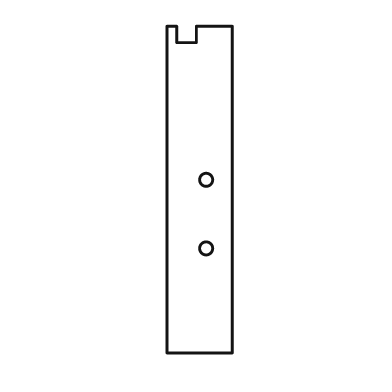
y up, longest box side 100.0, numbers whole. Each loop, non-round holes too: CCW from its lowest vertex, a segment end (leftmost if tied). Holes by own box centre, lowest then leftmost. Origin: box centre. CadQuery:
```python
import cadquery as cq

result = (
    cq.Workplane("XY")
    .moveTo(-10.0, -50.0)
    .lineTo(10.0, -50.0)
    .lineTo(10.0, 50.0)
    .lineTo(-1.0, 50.0)
    .lineTo(-1.0, 45.0)
    .lineTo(-7.0, 45.0)
    .lineTo(-7.0, 50.0)
    .lineTo(-10.0, 50.0)
    .close()
    .moveTo(2.0, -18.0)
    .circle(2.0)
    .moveTo(2.0, 3.0)
    .circle(2.0)
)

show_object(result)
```